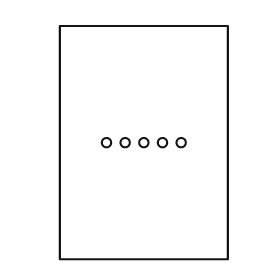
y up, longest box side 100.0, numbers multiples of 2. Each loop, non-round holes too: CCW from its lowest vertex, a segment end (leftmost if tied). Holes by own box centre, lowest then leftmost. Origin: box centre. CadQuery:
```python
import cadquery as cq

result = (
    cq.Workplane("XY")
    .moveTo(-36.0, -50.0)
    .lineTo(36.0, -50.0)
    .lineTo(36.0, 50.0)
    .lineTo(-36.0, 50.0)
    .close()
    .moveTo(-16.0, 0.0)
    .circle(2.0)
    .moveTo(-8.0, 0.0)
    .circle(2.0)
    .moveTo(0.0, 0.0)
    .circle(2.0)
    .moveTo(8.0, 0.0)
    .circle(2.0)
    .moveTo(16.0, 0.0)
    .circle(2.0)
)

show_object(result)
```